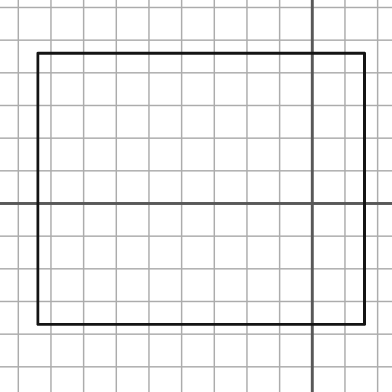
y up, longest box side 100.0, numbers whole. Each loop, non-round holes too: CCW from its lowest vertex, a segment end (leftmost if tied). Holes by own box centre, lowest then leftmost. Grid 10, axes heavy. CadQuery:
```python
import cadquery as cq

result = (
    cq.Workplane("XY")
    .moveTo(-84.0, -37.0)
    .lineTo(16.0, -37.0)
    .lineTo(16.0, 46.0)
    .lineTo(-84.0, 46.0)
    .close()
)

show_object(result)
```